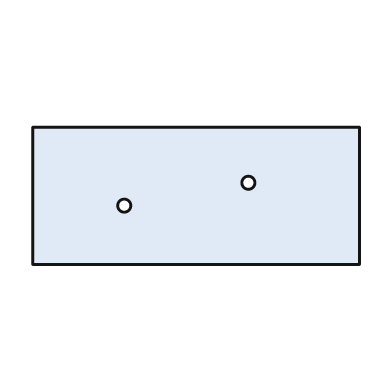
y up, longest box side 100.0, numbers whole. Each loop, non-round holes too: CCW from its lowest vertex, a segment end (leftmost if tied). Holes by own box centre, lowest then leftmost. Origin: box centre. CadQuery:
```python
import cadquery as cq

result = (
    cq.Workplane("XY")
    .moveTo(-50.0, -21.0)
    .lineTo(50.0, -21.0)
    .lineTo(50.0, 21.0)
    .lineTo(-50.0, 21.0)
    .close()
    .moveTo(-22.0, -3.0)
    .circle(2.0)
    .moveTo(16.0, 4.0)
    .circle(2.0)
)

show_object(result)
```